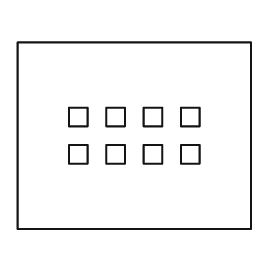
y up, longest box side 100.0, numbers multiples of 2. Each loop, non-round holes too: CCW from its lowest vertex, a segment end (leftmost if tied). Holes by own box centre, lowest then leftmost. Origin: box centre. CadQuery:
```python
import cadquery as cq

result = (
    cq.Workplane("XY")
    .moveTo(-50.0, -40.0)
    .lineTo(50.0, -40.0)
    .lineTo(50.0, 40.0)
    .lineTo(-50.0, 40.0)
    .close()
    .moveTo(-28.0, -12.0)
    .lineTo(-20.0, -12.0)
    .lineTo(-20.0, -4.0)
    .lineTo(-28.0, -4.0)
    .close()
    .moveTo(-12.0, -12.0)
    .lineTo(-4.0, -12.0)
    .lineTo(-4.0, -4.0)
    .lineTo(-12.0, -4.0)
    .close()
    .moveTo(4.0, -12.0)
    .lineTo(12.0, -12.0)
    .lineTo(12.0, -4.0)
    .lineTo(4.0, -4.0)
    .close()
    .moveTo(20.0, -12.0)
    .lineTo(28.0, -12.0)
    .lineTo(28.0, -4.0)
    .lineTo(20.0, -4.0)
    .close()
    .moveTo(-28.0, 4.0)
    .lineTo(-20.0, 4.0)
    .lineTo(-20.0, 12.0)
    .lineTo(-28.0, 12.0)
    .close()
    .moveTo(-12.0, 4.0)
    .lineTo(-4.0, 4.0)
    .lineTo(-4.0, 12.0)
    .lineTo(-12.0, 12.0)
    .close()
    .moveTo(4.0, 4.0)
    .lineTo(12.0, 4.0)
    .lineTo(12.0, 12.0)
    .lineTo(4.0, 12.0)
    .close()
    .moveTo(20.0, 4.0)
    .lineTo(28.0, 4.0)
    .lineTo(28.0, 12.0)
    .lineTo(20.0, 12.0)
    .close()
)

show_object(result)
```